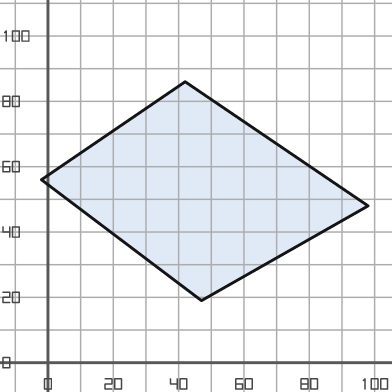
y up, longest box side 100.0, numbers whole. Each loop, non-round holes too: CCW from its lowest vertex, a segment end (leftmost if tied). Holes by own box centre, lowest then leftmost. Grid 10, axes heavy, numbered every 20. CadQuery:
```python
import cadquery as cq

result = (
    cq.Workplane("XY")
    .moveTo(47.0, 19.0)
    .lineTo(98.0, 48.0)
    .lineTo(42.0, 86.0)
    .lineTo(-2.0, 56.0)
    .close()
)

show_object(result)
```